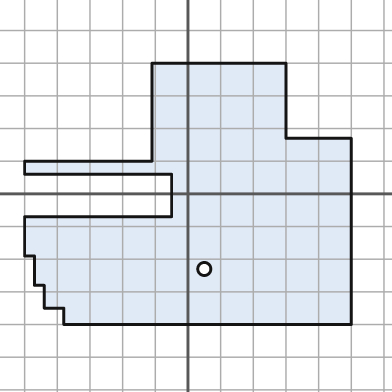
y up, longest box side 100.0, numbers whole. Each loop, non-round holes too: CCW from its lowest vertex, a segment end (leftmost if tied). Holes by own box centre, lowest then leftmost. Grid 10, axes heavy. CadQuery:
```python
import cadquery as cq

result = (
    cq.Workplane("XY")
    .moveTo(-38.0, -40.0)
    .lineTo(50.0, -40.0)
    .lineTo(50.0, 17.0)
    .lineTo(30.0, 17.0)
    .lineTo(30.0, 40.0)
    .lineTo(-11.0, 40.0)
    .lineTo(-11.0, 10.0)
    .lineTo(-50.0, 10.0)
    .lineTo(-50.0, 6.0)
    .lineTo(-5.0, 6.0)
    .lineTo(-5.0, -7.0)
    .lineTo(-50.0, -7.0)
    .lineTo(-50.0, -19.0)
    .lineTo(-47.0, -19.0)
    .lineTo(-47.0, -28.0)
    .lineTo(-44.0, -28.0)
    .lineTo(-44.0, -35.0)
    .lineTo(-38.0, -35.0)
    .close()
    .moveTo(5.0, -23.0)
    .circle(2.0)
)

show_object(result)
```